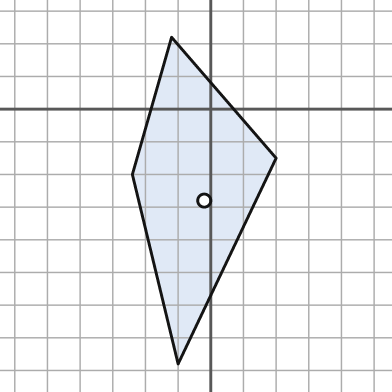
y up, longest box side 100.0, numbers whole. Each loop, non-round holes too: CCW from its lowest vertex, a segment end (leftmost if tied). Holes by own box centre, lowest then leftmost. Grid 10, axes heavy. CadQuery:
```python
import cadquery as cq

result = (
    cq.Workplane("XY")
    .moveTo(-10.0, -78.0)
    .lineTo(20.0, -15.0)
    .lineTo(-12.0, 22.0)
    .lineTo(-24.0, -20.0)
    .close()
    .moveTo(-2.0, -28.0)
    .circle(2.0)
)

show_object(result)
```